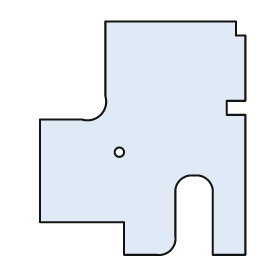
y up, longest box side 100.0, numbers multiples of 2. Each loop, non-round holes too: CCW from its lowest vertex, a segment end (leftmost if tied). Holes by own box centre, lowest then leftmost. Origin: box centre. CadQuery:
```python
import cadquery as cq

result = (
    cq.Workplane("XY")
    .moveTo(-8.0, -50.0)
    .lineTo(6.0, -50.0)
    .threePointArc((12.0, -48.0), (14.0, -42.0))
    .lineTo(14.0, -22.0)
    .threePointArc((16.0, -18.0), (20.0, -16.0))
    .lineTo(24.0, -16.0)
    .threePointArc((28.0, -18.0), (30.0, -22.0))
    .lineTo(30.0, -50.0)
    .lineTo(44.0, -50.0)
    .lineTo(44.0, 10.0)
    .lineTo(36.0, 10.0)
    .lineTo(36.0, 16.0)
    .lineTo(44.0, 16.0)
    .lineTo(44.0, 44.0)
    .lineTo(40.0, 44.0)
    .lineTo(40.0, 50.0)
    .lineTo(-16.0, 50.0)
    .lineTo(-16.0, 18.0)
    .threePointArc((-18.0, 10.0), (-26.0, 8.0))
    .lineTo(-44.0, 8.0)
    .lineTo(-44.0, -36.0)
    .lineTo(-8.0, -36.0)
    .close()
    .moveTo(-10.0, -6.0)
    .circle(2.0)
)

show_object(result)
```